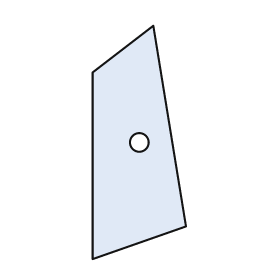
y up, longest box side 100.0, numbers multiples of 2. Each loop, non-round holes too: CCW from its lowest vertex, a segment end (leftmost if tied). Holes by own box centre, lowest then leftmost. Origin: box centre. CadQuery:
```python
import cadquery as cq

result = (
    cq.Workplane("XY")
    .moveTo(-20.0, -50.0)
    .lineTo(20.0, -36.0)
    .lineTo(6.0, 50.0)
    .lineTo(-20.0, 30.0)
    .close()
    .moveTo(0.0, 0.0)
    .circle(4.0)
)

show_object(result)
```